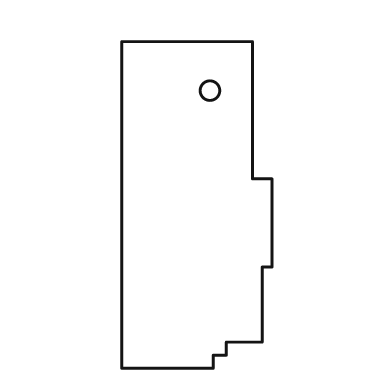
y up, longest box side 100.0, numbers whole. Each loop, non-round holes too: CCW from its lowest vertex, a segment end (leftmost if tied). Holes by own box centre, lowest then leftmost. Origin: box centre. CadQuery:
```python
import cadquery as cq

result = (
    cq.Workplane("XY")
    .moveTo(-23.0, -50.0)
    .lineTo(5.0, -50.0)
    .lineTo(5.0, -46.0)
    .lineTo(9.0, -46.0)
    .lineTo(9.0, -42.0)
    .lineTo(20.0, -42.0)
    .lineTo(20.0, -19.0)
    .lineTo(23.0, -19.0)
    .lineTo(23.0, 8.0)
    .lineTo(17.0, 8.0)
    .lineTo(17.0, 50.0)
    .lineTo(-23.0, 50.0)
    .close()
    .moveTo(4.0, 35.0)
    .circle(3.0)
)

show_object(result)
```